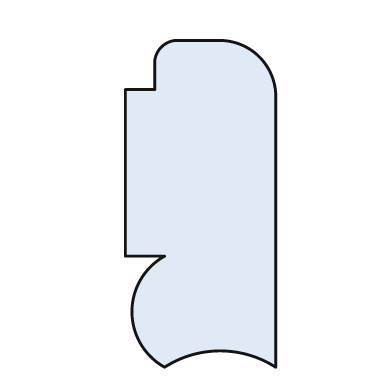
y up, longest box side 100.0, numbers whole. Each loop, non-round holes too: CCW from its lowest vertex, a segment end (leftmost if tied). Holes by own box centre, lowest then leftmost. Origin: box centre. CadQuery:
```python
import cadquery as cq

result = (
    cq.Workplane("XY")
    .moveTo(-11.0, -50.0)
    .threePointArc((6.0, -45.0), (23.0, -50.0))
    .lineTo(23.0, 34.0)
    .threePointArc((18.0, 45.0), (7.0, 50.0))
    .lineTo(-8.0, 50.0)
    .threePointArc((-12.0, 48.0), (-14.0, 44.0))
    .lineTo(-14.0, 35.0)
    .lineTo(-23.0, 35.0)
    .lineTo(-23.0, -16.0)
    .lineTo(-11.0, -16.0)
    .threePointArc((-21.0, -33.0), (-11.0, -50.0))
    .close()
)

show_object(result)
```